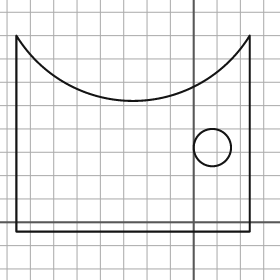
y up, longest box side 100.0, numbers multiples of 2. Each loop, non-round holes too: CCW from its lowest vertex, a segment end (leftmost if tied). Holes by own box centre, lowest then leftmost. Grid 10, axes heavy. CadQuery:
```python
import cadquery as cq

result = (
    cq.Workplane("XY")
    .moveTo(-76.0, -4.0)
    .lineTo(24.0, -4.0)
    .lineTo(24.0, 80.0)
    .threePointArc((-26.0, 52.0), (-76.0, 80.0))
    .close()
    .moveTo(8.0, 32.0)
    .circle(8.0)
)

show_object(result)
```